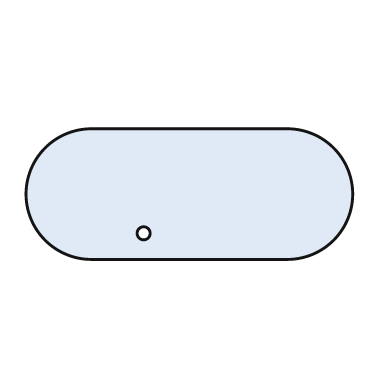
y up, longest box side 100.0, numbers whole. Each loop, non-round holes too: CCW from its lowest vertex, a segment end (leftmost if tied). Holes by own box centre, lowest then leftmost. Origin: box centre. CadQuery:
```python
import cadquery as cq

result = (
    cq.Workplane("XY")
    .moveTo(-30.0, -20.0)
    .lineTo(30.0, -20.0)
    .threePointArc((50.0, 0.0), (30.0, 20.0))
    .lineTo(-30.0, 20.0)
    .threePointArc((-50.0, 0.0), (-30.0, -20.0))
    .close()
    .moveTo(-14.0, -12.0)
    .circle(2.0)
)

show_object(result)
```